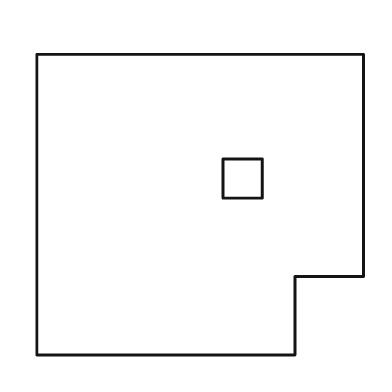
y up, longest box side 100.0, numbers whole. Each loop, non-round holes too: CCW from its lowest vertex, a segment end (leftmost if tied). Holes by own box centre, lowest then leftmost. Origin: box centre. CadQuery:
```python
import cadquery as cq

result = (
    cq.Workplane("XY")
    .moveTo(-50.0, -46.0)
    .lineTo(29.0, -46.0)
    .lineTo(29.0, -22.0)
    .lineTo(50.0, -22.0)
    .lineTo(50.0, 46.0)
    .lineTo(-50.0, 46.0)
    .close()
    .moveTo(7.0, 2.0)
    .lineTo(19.0, 2.0)
    .lineTo(19.0, 14.0)
    .lineTo(7.0, 14.0)
    .close()
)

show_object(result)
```